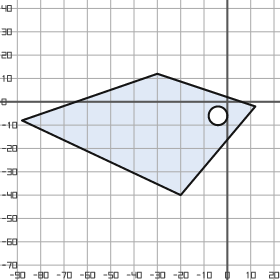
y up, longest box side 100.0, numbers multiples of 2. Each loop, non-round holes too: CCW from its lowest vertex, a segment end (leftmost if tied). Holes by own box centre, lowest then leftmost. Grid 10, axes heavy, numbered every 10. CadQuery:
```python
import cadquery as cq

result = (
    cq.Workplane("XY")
    .moveTo(-20.0, -40.0)
    .lineTo(12.0, -2.0)
    .lineTo(-30.0, 12.0)
    .lineTo(-88.0, -8.0)
    .close()
    .moveTo(-4.0, -6.0)
    .circle(4.0)
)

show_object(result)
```